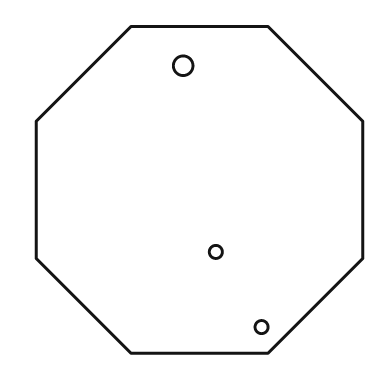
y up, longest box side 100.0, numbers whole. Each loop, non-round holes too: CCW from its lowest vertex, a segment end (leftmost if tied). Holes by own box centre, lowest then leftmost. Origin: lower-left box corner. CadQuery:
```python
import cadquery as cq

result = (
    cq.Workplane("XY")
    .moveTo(29.0, 0.0)
    .lineTo(71.0, 0.0)
    .lineTo(100.0, 29.0)
    .lineTo(100.0, 71.0)
    .lineTo(71.0, 100.0)
    .lineTo(29.0, 100.0)
    .lineTo(0.0, 71.0)
    .lineTo(0.0, 29.0)
    .close()
    .moveTo(69.0, 8.0)
    .circle(2.0)
    .moveTo(55.0, 31.0)
    .circle(2.0)
    .moveTo(45.0, 88.0)
    .circle(3.0)
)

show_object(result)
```